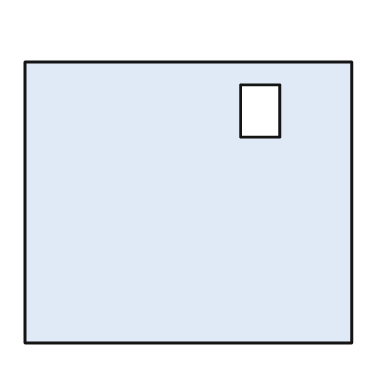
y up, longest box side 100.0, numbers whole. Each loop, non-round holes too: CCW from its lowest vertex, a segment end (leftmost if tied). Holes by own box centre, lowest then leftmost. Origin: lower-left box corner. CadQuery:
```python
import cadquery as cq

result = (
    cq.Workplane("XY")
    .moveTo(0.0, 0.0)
    .lineTo(100.0, 0.0)
    .lineTo(100.0, 86.0)
    .lineTo(0.0, 86.0)
    .close()
    .moveTo(66.0, 63.0)
    .lineTo(78.0, 63.0)
    .lineTo(78.0, 79.0)
    .lineTo(66.0, 79.0)
    .close()
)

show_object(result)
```